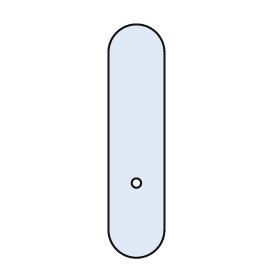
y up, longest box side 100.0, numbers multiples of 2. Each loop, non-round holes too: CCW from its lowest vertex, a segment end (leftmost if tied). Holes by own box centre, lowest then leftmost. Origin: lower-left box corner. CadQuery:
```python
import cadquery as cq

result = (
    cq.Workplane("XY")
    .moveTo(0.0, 12.0)
    .threePointArc((12.0, 0.0), (24.0, 12.0))
    .lineTo(24.0, 88.0)
    .threePointArc((12.0, 100.0), (0.0, 88.0))
    .close()
    .moveTo(12.0, 32.0)
    .circle(2.0)
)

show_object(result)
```